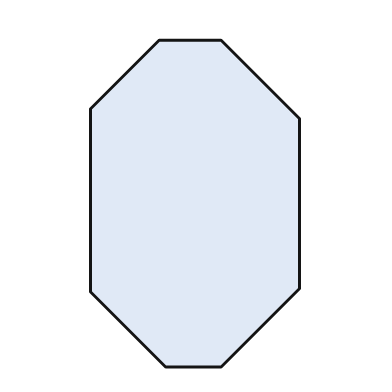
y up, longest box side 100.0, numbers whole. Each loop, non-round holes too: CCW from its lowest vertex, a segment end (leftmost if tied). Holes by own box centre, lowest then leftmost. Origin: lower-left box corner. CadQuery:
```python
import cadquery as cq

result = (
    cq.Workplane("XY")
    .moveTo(23.0, 0.0)
    .lineTo(40.0, 0.0)
    .lineTo(64.0, 24.0)
    .lineTo(64.0, 76.0)
    .lineTo(40.0, 100.0)
    .lineTo(21.0, 100.0)
    .lineTo(0.0, 79.0)
    .lineTo(0.0, 23.0)
    .close()
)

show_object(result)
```